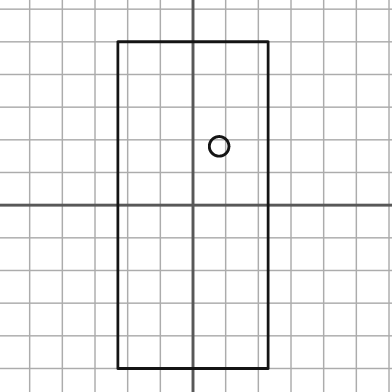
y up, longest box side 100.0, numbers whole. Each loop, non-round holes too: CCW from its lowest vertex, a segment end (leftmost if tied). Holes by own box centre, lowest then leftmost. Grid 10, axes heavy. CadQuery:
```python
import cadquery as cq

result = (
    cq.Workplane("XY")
    .moveTo(-23.0, -50.0)
    .lineTo(23.0, -50.0)
    .lineTo(23.0, 50.0)
    .lineTo(-23.0, 50.0)
    .close()
    .moveTo(8.0, 18.0)
    .circle(3.0)
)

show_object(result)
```